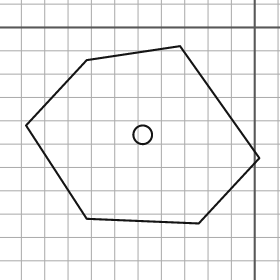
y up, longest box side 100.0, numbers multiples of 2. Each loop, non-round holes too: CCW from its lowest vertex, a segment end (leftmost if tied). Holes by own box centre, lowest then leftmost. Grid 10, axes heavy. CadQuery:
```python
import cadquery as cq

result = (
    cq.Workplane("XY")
    .moveTo(-24.0, -84.0)
    .lineTo(2.0, -56.0)
    .lineTo(-32.0, -8.0)
    .lineTo(-72.0, -14.0)
    .lineTo(-98.0, -42.0)
    .lineTo(-72.0, -82.0)
    .close()
    .moveTo(-48.0, -46.0)
    .circle(4.0)
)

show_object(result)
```